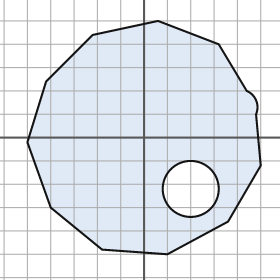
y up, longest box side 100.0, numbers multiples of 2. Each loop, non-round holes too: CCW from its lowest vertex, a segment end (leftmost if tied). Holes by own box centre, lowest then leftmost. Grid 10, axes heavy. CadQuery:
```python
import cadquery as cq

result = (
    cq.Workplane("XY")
    .moveTo(10.0, -50.0)
    .lineTo(36.0, -36.0)
    .lineTo(50.0, -12.0)
    .lineTo(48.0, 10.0)
    .threePointArc((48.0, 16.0), (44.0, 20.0))
    .lineTo(32.0, 40.0)
    .lineTo(6.0, 50.0)
    .lineTo(-22.0, 44.0)
    .lineTo(-42.0, 24.0)
    .lineTo(-50.0, -2.0)
    .lineTo(-40.0, -30.0)
    .lineTo(-18.0, -48.0)
    .close()
    .moveTo(20.0, -22.0)
    .circle(12.0)
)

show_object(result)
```